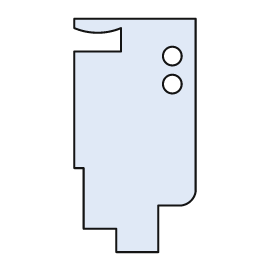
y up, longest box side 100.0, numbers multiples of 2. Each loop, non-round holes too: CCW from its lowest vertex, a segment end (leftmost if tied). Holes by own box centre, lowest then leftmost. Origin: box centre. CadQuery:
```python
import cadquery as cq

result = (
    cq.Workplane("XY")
    .moveTo(-8.0, -50.0)
    .lineTo(10.0, -50.0)
    .lineTo(10.0, -30.0)
    .lineTo(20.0, -30.0)
    .threePointArc((24.0, -28.0), (26.0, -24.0))
    .lineTo(26.0, 50.0)
    .lineTo(-26.0, 50.0)
    .lineTo(-26.0, 46.0)
    .threePointArc((-16.0, 44.0), (-6.0, 46.0))
    .lineTo(-6.0, 36.0)
    .lineTo(-26.0, 36.0)
    .lineTo(-26.0, -14.0)
    .lineTo(-22.0, -14.0)
    .lineTo(-22.0, -40.0)
    .lineTo(-8.0, -40.0)
    .close()
    .moveTo(16.0, 22.0)
    .circle(4.0)
    .moveTo(16.0, 34.0)
    .circle(4.0)
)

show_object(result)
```